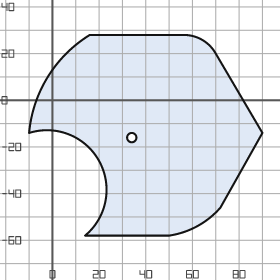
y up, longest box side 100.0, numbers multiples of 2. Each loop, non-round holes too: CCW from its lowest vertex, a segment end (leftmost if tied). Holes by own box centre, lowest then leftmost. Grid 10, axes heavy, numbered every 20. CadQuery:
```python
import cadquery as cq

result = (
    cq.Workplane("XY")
    .moveTo(14.0, -58.0)
    .lineTo(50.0, -58.0)
    .threePointArc((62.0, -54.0), (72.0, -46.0))
    .lineTo(90.0, -14.0)
    .lineTo(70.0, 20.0)
    .threePointArc((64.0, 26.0), (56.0, 28.0))
    .lineTo(16.0, 28.0)
    .threePointArc((-2.0, 10.0), (-10.0, -14.0))
    .threePointArc((20.0, -26.0), (14.0, -58.0))
    .close()
    .moveTo(34.0, -16.0)
    .circle(2.0)
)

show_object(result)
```